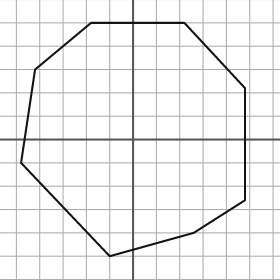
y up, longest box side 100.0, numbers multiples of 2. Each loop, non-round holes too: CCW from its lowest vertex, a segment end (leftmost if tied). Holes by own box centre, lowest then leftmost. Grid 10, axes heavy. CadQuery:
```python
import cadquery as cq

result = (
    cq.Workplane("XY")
    .moveTo(-10.0, -50.0)
    .lineTo(26.0, -40.0)
    .lineTo(48.0, -26.0)
    .lineTo(48.0, 22.0)
    .lineTo(22.0, 50.0)
    .lineTo(-18.0, 50.0)
    .lineTo(-42.0, 30.0)
    .lineTo(-48.0, -10.0)
    .close()
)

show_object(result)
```